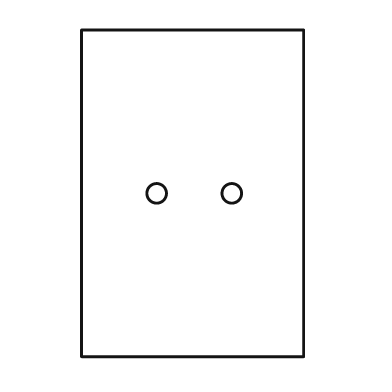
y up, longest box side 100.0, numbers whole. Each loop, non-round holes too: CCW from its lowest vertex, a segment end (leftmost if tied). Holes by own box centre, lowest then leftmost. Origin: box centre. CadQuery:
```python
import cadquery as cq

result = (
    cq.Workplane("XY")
    .moveTo(-34.0, -50.0)
    .lineTo(34.0, -50.0)
    .lineTo(34.0, 50.0)
    .lineTo(-34.0, 50.0)
    .close()
    .moveTo(-11.0, 0.0)
    .circle(3.0)
    .moveTo(12.0, 0.0)
    .circle(3.0)
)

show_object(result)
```